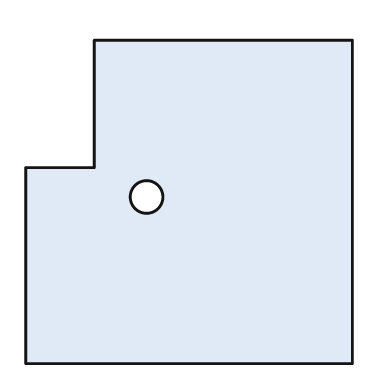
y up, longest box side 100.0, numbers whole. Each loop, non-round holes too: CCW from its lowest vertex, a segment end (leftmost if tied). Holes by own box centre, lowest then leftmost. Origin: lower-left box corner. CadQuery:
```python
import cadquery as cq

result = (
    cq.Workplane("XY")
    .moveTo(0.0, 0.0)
    .lineTo(100.0, 0.0)
    .lineTo(100.0, 99.0)
    .lineTo(21.0, 99.0)
    .lineTo(21.0, 60.0)
    .lineTo(0.0, 60.0)
    .close()
    .moveTo(37.0, 51.0)
    .circle(5.0)
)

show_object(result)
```